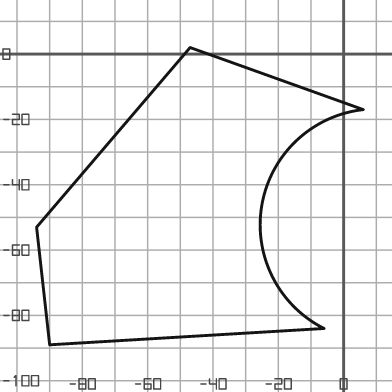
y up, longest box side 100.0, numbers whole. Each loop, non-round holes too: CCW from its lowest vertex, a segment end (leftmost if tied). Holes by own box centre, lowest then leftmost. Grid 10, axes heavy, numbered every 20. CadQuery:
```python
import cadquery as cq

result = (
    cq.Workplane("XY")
    .moveTo(-90.0, -89.0)
    .lineTo(-6.0, -84.0)
    .threePointArc((-25.0, -46.0), (6.0, -17.0))
    .lineTo(-47.0, 2.0)
    .lineTo(-94.0, -53.0)
    .close()
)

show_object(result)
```